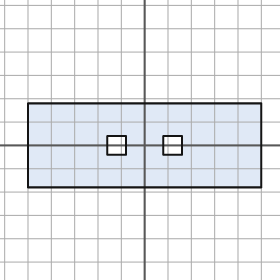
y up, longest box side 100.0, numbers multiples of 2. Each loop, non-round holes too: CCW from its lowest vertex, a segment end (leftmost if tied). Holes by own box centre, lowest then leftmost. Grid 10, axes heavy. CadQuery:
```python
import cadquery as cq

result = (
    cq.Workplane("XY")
    .moveTo(-50.0, -18.0)
    .lineTo(50.0, -18.0)
    .lineTo(50.0, 18.0)
    .lineTo(-50.0, 18.0)
    .close()
    .moveTo(-16.0, -4.0)
    .lineTo(-8.0, -4.0)
    .lineTo(-8.0, 4.0)
    .lineTo(-16.0, 4.0)
    .close()
    .moveTo(8.0, -4.0)
    .lineTo(16.0, -4.0)
    .lineTo(16.0, 4.0)
    .lineTo(8.0, 4.0)
    .close()
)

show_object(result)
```